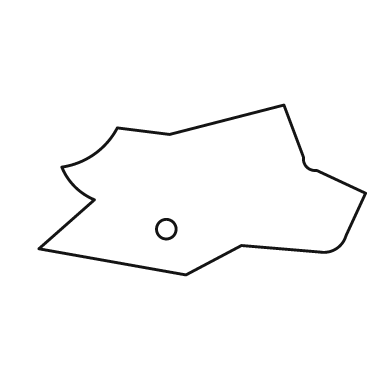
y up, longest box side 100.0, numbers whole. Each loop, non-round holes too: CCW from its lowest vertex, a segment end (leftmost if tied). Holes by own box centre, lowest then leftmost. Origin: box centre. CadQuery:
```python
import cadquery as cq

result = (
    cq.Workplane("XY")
    .moveTo(-5.0, -26.0)
    .lineTo(12.0, -17.0)
    .lineTo(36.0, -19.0)
    .threePointArc((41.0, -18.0), (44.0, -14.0))
    .lineTo(50.0, -1.0)
    .lineTo(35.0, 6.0)
    .threePointArc((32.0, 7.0), (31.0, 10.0))
    .lineTo(25.0, 26.0)
    .lineTo(-10.0, 17.0)
    .lineTo(-26.0, 19.0)
    .threePointArc((-33.0, 11.0), (-43.0, 7.0))
    .threePointArc((-39.0, 1.0), (-33.0, -3.0))
    .lineTo(-50.0, -18.0)
    .close()
    .moveTo(-11.0, -12.0)
    .circle(3.0)
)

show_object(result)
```